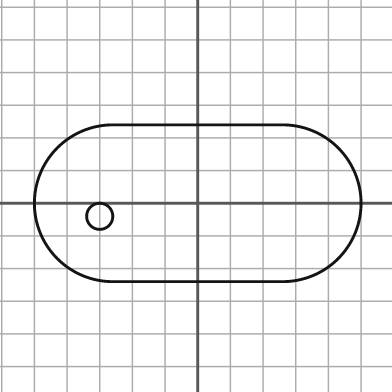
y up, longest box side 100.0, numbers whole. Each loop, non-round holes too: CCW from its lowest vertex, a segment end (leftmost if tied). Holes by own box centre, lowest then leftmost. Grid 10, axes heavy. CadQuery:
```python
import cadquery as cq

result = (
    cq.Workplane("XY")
    .moveTo(-26.0, -24.0)
    .lineTo(26.0, -24.0)
    .threePointArc((50.0, 0.0), (26.0, 24.0))
    .lineTo(-26.0, 24.0)
    .threePointArc((-50.0, 0.0), (-26.0, -24.0))
    .close()
    .moveTo(-30.0, -4.0)
    .circle(4.0)
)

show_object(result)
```